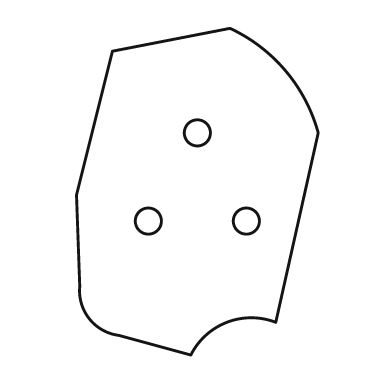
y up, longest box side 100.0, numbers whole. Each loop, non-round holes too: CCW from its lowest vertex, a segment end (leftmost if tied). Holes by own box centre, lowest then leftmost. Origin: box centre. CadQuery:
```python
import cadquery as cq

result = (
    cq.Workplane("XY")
    .moveTo(-2.0, -50.0)
    .threePointArc((9.0, -40.0), (24.0, -40.0))
    .lineTo(37.0, 18.0)
    .threePointArc((27.0, 37.0), (10.0, 50.0))
    .lineTo(-26.0, 43.0)
    .lineTo(-37.0, -1.0)
    .lineTo(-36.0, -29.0)
    .threePointArc((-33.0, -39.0), (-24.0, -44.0))
    .close()
    .moveTo(-15.0, -9.0)
    .circle(4.0)
    .moveTo(15.0, -9.0)
    .circle(4.0)
    .moveTo(0.0, 18.0)
    .circle(4.0)
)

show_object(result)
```